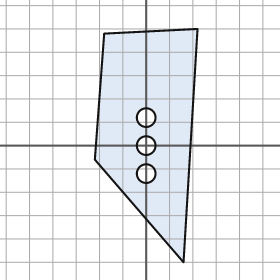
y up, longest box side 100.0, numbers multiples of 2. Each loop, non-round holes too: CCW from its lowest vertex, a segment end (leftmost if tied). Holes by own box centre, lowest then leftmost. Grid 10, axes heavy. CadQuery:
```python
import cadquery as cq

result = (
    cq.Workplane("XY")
    .moveTo(16.0, -50.0)
    .lineTo(22.0, 50.0)
    .lineTo(-18.0, 48.0)
    .lineTo(-22.0, -6.0)
    .close()
    .moveTo(0.0, -12.0)
    .circle(4.0)
    .moveTo(0.0, 0.0)
    .circle(4.0)
    .moveTo(0.0, 12.0)
    .circle(4.0)
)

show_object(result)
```